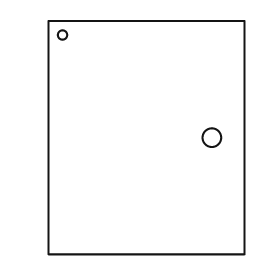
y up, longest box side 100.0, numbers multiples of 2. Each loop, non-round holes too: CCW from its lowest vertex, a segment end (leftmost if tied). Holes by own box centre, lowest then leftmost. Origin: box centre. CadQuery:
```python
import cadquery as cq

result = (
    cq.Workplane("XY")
    .moveTo(-42.0, -50.0)
    .lineTo(42.0, -50.0)
    .lineTo(42.0, 50.0)
    .lineTo(-42.0, 50.0)
    .close()
    .moveTo(28.0, 0.0)
    .circle(4.0)
    .moveTo(-36.0, 44.0)
    .circle(2.0)
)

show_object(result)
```